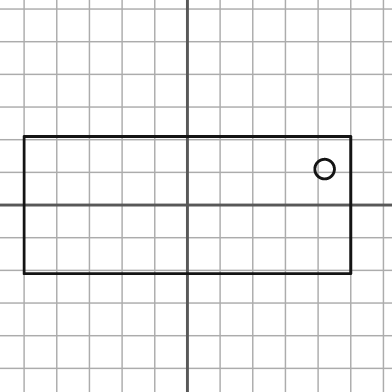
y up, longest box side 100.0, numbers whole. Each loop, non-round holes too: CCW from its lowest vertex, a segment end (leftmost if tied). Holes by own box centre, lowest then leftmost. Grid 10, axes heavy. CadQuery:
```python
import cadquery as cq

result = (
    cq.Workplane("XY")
    .moveTo(-50.0, -21.0)
    .lineTo(50.0, -21.0)
    .lineTo(50.0, 21.0)
    .lineTo(-50.0, 21.0)
    .close()
    .moveTo(42.0, 11.0)
    .circle(3.0)
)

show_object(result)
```